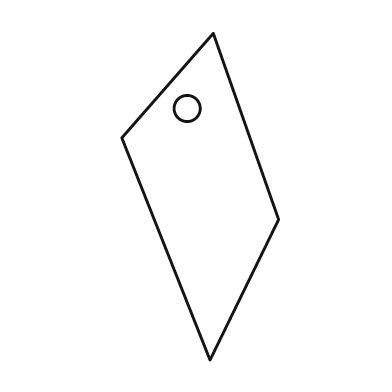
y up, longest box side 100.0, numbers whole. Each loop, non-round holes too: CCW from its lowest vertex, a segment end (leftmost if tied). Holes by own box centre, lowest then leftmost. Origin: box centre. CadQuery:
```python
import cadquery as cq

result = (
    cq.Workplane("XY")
    .moveTo(3.0, -50.0)
    .lineTo(24.0, -7.0)
    .lineTo(4.0, 50.0)
    .lineTo(-24.0, 18.0)
    .close()
    .moveTo(-4.0, 27.0)
    .circle(4.0)
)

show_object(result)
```